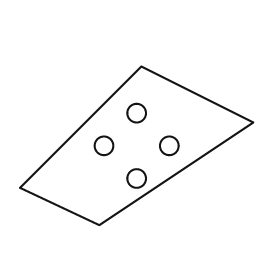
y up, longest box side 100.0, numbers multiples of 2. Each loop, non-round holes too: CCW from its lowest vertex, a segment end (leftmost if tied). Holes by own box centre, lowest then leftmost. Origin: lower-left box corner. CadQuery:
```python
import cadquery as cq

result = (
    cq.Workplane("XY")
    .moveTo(34.0, 0.0)
    .lineTo(100.0, 44.0)
    .lineTo(52.0, 68.0)
    .lineTo(0.0, 16.0)
    .close()
    .moveTo(50.0, 20.0)
    .circle(4.0)
    .moveTo(36.0, 34.0)
    .circle(4.0)
    .moveTo(64.0, 34.0)
    .circle(4.0)
    .moveTo(50.0, 48.0)
    .circle(4.0)
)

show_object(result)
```